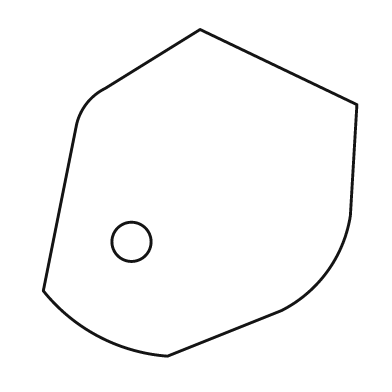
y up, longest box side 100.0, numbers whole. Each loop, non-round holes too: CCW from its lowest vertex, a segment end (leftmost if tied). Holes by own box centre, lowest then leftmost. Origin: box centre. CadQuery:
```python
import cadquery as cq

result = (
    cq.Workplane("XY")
    .moveTo(-10.0, -50.0)
    .lineTo(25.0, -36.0)
    .threePointArc((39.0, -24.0), (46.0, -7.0))
    .lineTo(48.0, 27.0)
    .lineTo(0.0, 50.0)
    .lineTo(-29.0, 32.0)
    .threePointArc((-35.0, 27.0), (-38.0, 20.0))
    .lineTo(-48.0, -30.0)
    .threePointArc((-31.0, -44.0), (-10.0, -50.0))
    .close()
    .moveTo(-21.0, -15.0)
    .circle(6.0)
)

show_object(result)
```